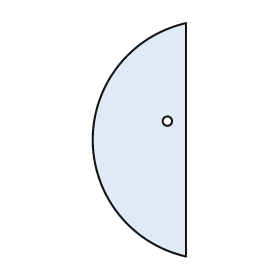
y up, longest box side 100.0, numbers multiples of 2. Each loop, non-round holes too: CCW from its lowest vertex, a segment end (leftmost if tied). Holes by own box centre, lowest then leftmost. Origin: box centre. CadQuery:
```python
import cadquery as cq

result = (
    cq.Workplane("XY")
    .moveTo(20.0, -50.0)
    .lineTo(20.0, 50.0)
    .threePointArc((-20.0, 0.0), (20.0, -50.0))
    .close()
    .moveTo(12.0, 8.0)
    .circle(2.0)
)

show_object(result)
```